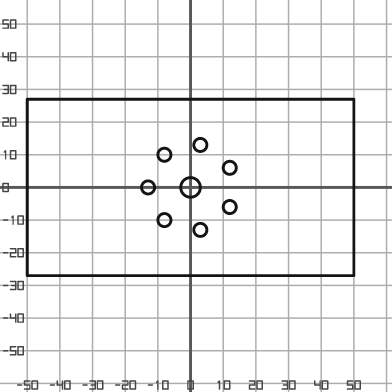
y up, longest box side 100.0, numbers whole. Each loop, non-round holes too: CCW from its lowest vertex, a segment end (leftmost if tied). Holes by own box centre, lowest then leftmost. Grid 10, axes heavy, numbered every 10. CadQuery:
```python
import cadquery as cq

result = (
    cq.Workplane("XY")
    .moveTo(-50.0, -27.0)
    .lineTo(50.0, -27.0)
    .lineTo(50.0, 27.0)
    .lineTo(-50.0, 27.0)
    .close()
    .moveTo(3.0, -13.0)
    .circle(2.0)
    .moveTo(-8.0, -10.0)
    .circle(2.0)
    .moveTo(12.0, -6.0)
    .circle(2.0)
    .moveTo(-13.0, 0.0)
    .circle(2.0)
    .moveTo(0.0, 0.0)
    .circle(3.0)
    .moveTo(12.0, 6.0)
    .circle(2.0)
    .moveTo(-8.0, 10.0)
    .circle(2.0)
    .moveTo(3.0, 13.0)
    .circle(2.0)
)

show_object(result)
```